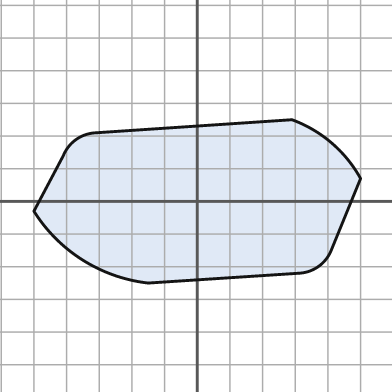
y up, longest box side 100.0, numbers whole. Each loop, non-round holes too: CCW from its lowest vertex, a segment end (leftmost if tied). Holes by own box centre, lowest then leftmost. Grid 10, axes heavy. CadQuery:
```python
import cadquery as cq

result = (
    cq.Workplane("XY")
    .moveTo(-15.0, -25.0)
    .lineTo(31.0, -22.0)
    .threePointArc((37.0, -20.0), (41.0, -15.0))
    .lineTo(50.0, 7.0)
    .threePointArc((41.0, 18.0), (29.0, 25.0))
    .lineTo(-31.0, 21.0)
    .threePointArc((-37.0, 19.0), (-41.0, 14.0))
    .lineTo(-50.0, -3.0)
    .threePointArc((-35.0, -18.0), (-15.0, -25.0))
    .close()
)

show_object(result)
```